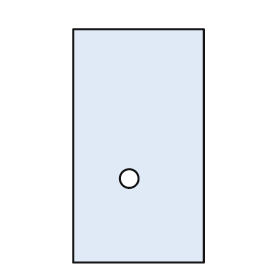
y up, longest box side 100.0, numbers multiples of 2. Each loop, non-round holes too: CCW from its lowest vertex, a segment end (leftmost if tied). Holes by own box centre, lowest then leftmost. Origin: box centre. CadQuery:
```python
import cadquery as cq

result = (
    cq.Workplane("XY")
    .moveTo(-28.0, -50.0)
    .lineTo(28.0, -50.0)
    .lineTo(28.0, 50.0)
    .lineTo(-28.0, 50.0)
    .close()
    .moveTo(-4.0, -14.0)
    .circle(4.0)
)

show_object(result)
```